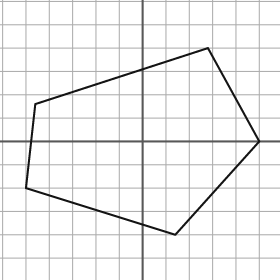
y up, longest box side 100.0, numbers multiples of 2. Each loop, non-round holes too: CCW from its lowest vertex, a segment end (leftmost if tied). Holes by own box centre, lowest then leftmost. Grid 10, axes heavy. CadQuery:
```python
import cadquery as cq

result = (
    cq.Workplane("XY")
    .moveTo(14.0, -40.0)
    .lineTo(50.0, 0.0)
    .lineTo(28.0, 40.0)
    .lineTo(-46.0, 16.0)
    .lineTo(-50.0, -20.0)
    .close()
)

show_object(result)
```